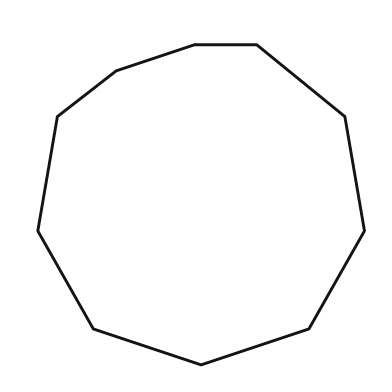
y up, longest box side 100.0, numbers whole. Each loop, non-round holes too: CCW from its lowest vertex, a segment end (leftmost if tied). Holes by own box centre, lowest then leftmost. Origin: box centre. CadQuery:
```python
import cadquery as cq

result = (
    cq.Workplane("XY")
    .moveTo(0.0, -49.0)
    .lineTo(33.0, -38.0)
    .lineTo(50.0, -8.0)
    .lineTo(44.0, 27.0)
    .lineTo(17.0, 49.0)
    .lineTo(-2.0, 49.0)
    .lineTo(-26.0, 41.0)
    .lineTo(-44.0, 27.0)
    .lineTo(-50.0, -8.0)
    .lineTo(-33.0, -38.0)
    .close()
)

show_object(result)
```